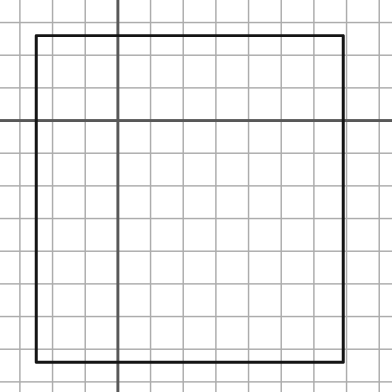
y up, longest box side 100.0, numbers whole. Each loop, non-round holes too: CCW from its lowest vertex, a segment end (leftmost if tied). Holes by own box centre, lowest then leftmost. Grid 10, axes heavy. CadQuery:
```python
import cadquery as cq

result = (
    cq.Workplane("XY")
    .moveTo(-25.0, -74.0)
    .lineTo(69.0, -74.0)
    .lineTo(69.0, 26.0)
    .lineTo(-25.0, 26.0)
    .close()
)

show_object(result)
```